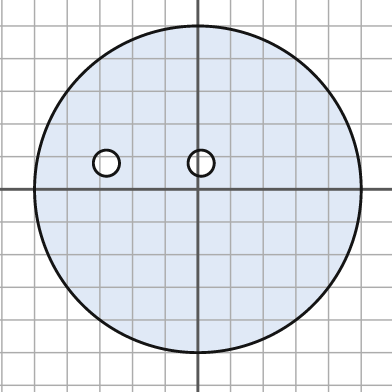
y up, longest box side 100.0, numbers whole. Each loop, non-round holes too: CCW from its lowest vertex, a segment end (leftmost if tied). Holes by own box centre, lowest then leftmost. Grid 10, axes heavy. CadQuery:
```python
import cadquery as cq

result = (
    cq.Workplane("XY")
    .moveTo(0.0, 0.0)
    .circle(50.0)
    .moveTo(-28.0, 8.0)
    .circle(4.0)
    .moveTo(1.0, 8.0)
    .circle(4.0)
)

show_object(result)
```